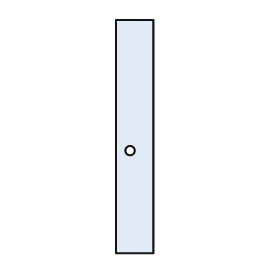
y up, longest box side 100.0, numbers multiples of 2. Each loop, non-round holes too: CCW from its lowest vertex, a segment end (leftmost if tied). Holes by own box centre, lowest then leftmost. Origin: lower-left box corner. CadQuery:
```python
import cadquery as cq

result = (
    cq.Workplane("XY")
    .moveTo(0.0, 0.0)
    .lineTo(16.0, 0.0)
    .lineTo(16.0, 100.0)
    .lineTo(0.0, 100.0)
    .close()
    .moveTo(6.0, 44.0)
    .circle(2.0)
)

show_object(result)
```